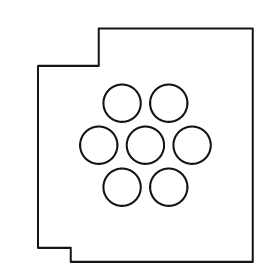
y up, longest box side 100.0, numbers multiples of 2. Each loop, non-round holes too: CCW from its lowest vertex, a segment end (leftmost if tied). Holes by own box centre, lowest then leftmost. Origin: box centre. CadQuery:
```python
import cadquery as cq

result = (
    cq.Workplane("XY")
    .moveTo(-32.0, -50.0)
    .lineTo(46.0, -50.0)
    .lineTo(46.0, 50.0)
    .lineTo(-20.0, 50.0)
    .lineTo(-20.0, 34.0)
    .lineTo(-46.0, 34.0)
    .lineTo(-46.0, -44.0)
    .lineTo(-32.0, -44.0)
    .close()
    .moveTo(-10.0, -18.0)
    .circle(8.0)
    .moveTo(10.0, -18.0)
    .circle(8.0)
    .moveTo(-20.0, 0.0)
    .circle(8.0)
    .moveTo(0.0, 0.0)
    .circle(8.0)
    .moveTo(20.0, 0.0)
    .circle(8.0)
    .moveTo(-10.0, 18.0)
    .circle(8.0)
    .moveTo(10.0, 18.0)
    .circle(8.0)
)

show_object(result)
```